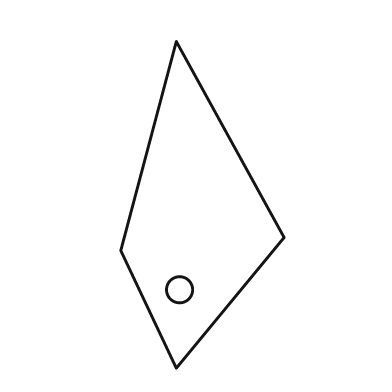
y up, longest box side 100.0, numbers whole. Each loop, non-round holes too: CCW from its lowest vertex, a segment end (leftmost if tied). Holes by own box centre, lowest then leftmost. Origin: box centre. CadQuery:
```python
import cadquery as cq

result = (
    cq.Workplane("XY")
    .moveTo(-8.0, -50.0)
    .lineTo(25.0, -10.0)
    .lineTo(-8.0, 50.0)
    .lineTo(-25.0, -14.0)
    .close()
    .moveTo(-7.0, -26.0)
    .circle(4.0)
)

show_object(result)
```